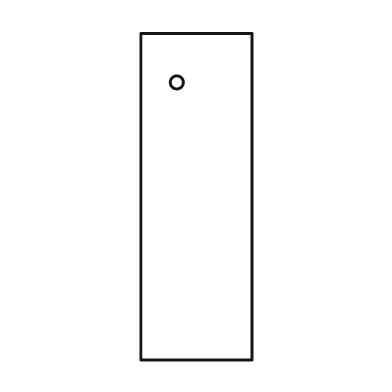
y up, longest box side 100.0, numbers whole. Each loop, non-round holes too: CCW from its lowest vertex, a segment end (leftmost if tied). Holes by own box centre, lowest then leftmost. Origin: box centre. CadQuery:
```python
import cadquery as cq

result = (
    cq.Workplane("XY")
    .moveTo(-17.0, -50.0)
    .lineTo(17.0, -50.0)
    .lineTo(17.0, 50.0)
    .lineTo(-17.0, 50.0)
    .close()
    .moveTo(-6.0, 35.0)
    .circle(2.0)
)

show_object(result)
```